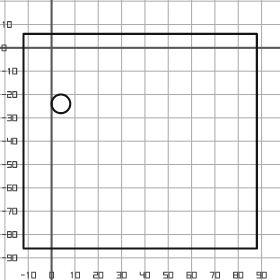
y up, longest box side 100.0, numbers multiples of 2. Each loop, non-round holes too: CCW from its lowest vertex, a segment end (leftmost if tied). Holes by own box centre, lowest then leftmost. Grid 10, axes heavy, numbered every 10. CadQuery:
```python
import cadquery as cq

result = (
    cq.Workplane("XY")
    .moveTo(-12.0, -86.0)
    .lineTo(88.0, -86.0)
    .lineTo(88.0, 6.0)
    .lineTo(-12.0, 6.0)
    .close()
    .moveTo(4.0, -24.0)
    .circle(4.0)
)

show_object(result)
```